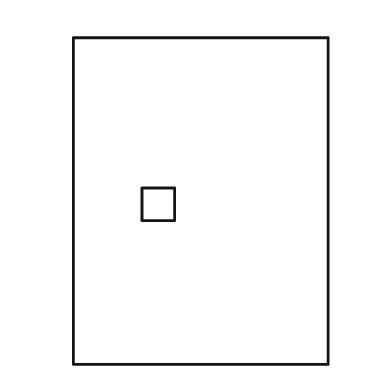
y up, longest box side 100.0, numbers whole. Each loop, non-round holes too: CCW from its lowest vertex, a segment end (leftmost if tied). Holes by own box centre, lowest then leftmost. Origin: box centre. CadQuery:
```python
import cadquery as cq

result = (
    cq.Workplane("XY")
    .moveTo(-39.0, -50.0)
    .lineTo(39.0, -50.0)
    .lineTo(39.0, 50.0)
    .lineTo(-39.0, 50.0)
    .close()
    .moveTo(-18.0, -6.0)
    .lineTo(-8.0, -6.0)
    .lineTo(-8.0, 4.0)
    .lineTo(-18.0, 4.0)
    .close()
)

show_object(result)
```